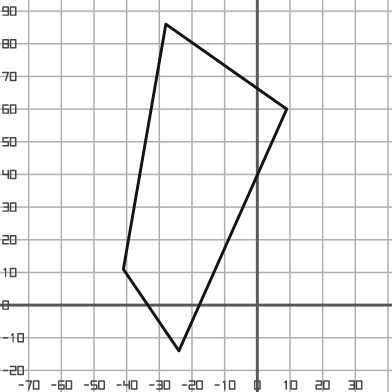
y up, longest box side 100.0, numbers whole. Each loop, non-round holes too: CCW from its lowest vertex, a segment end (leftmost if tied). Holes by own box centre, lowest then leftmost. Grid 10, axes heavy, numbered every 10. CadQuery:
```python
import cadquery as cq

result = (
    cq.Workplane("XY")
    .moveTo(-24.0, -14.0)
    .lineTo(9.0, 60.0)
    .lineTo(-28.0, 86.0)
    .lineTo(-41.0, 11.0)
    .close()
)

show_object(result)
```